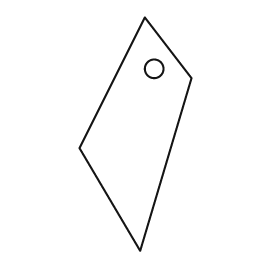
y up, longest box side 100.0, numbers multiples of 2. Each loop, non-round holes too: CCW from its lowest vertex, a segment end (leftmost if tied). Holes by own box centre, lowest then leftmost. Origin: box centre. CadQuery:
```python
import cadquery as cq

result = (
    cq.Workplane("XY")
    .moveTo(2.0, -50.0)
    .lineTo(24.0, 24.0)
    .lineTo(4.0, 50.0)
    .lineTo(-24.0, -6.0)
    .close()
    .moveTo(8.0, 28.0)
    .circle(4.0)
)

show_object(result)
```